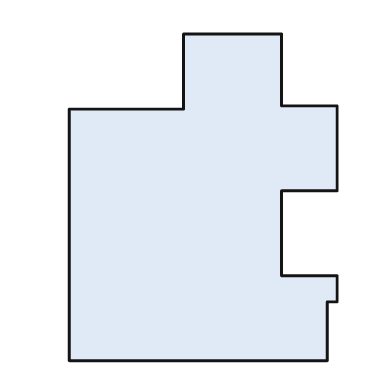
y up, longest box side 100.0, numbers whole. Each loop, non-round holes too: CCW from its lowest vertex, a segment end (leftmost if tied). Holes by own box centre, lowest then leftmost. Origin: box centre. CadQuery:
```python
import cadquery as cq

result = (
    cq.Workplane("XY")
    .moveTo(-41.0, -50.0)
    .lineTo(38.0, -50.0)
    .lineTo(38.0, -32.0)
    .lineTo(41.0, -32.0)
    .lineTo(41.0, -24.0)
    .lineTo(24.0, -24.0)
    .lineTo(24.0, 2.0)
    .lineTo(41.0, 2.0)
    .lineTo(41.0, 28.0)
    .lineTo(24.0, 28.0)
    .lineTo(24.0, 50.0)
    .lineTo(-6.0, 50.0)
    .lineTo(-6.0, 27.0)
    .lineTo(-41.0, 27.0)
    .close()
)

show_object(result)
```